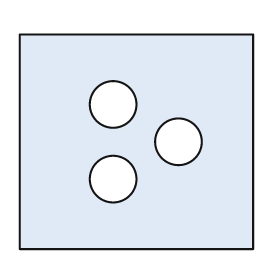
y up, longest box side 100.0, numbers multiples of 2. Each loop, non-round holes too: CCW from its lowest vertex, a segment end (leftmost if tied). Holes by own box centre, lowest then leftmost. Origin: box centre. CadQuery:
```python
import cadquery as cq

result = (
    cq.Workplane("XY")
    .moveTo(-50.0, -46.0)
    .lineTo(50.0, -46.0)
    .lineTo(50.0, 46.0)
    .lineTo(-50.0, 46.0)
    .close()
    .moveTo(-10.0, -16.0)
    .circle(10.0)
    .moveTo(18.0, 0.0)
    .circle(10.0)
    .moveTo(-10.0, 16.0)
    .circle(10.0)
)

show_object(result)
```